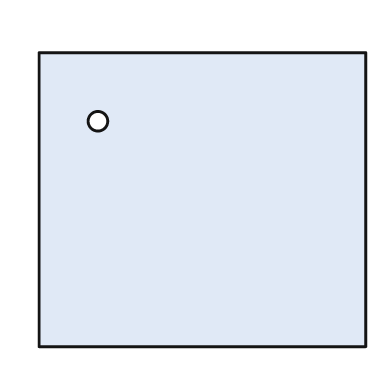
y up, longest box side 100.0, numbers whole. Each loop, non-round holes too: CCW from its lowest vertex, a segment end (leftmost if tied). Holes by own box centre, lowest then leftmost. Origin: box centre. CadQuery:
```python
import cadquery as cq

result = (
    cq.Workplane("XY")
    .moveTo(-50.0, -45.0)
    .lineTo(50.0, -45.0)
    .lineTo(50.0, 45.0)
    .lineTo(-50.0, 45.0)
    .close()
    .moveTo(-32.0, 24.0)
    .circle(3.0)
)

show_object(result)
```